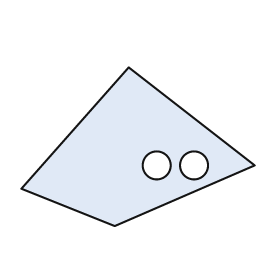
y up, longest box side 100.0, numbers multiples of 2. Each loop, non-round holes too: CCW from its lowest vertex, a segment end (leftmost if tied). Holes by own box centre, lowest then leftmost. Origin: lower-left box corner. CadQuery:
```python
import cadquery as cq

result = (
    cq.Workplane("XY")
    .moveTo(40.0, 0.0)
    .lineTo(100.0, 26.0)
    .lineTo(46.0, 68.0)
    .lineTo(0.0, 16.0)
    .close()
    .moveTo(58.0, 26.0)
    .circle(6.0)
    .moveTo(74.0, 26.0)
    .circle(6.0)
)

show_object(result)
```